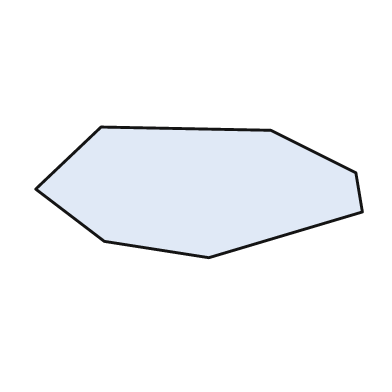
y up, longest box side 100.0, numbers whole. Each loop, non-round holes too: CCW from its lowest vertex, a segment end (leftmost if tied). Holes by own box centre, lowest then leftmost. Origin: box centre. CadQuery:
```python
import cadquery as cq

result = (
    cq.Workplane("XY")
    .moveTo(3.0, -20.0)
    .lineTo(50.0, -6.0)
    .lineTo(48.0, 6.0)
    .lineTo(22.0, 19.0)
    .lineTo(-30.0, 20.0)
    .lineTo(-50.0, 1.0)
    .lineTo(-29.0, -15.0)
    .close()
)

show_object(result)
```